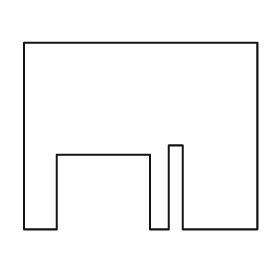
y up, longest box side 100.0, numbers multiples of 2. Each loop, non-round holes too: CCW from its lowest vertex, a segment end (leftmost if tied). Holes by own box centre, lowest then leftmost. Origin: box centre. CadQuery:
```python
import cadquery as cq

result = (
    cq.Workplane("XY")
    .moveTo(-50.0, -40.0)
    .lineTo(-36.0, -40.0)
    .lineTo(-36.0, -8.0)
    .lineTo(4.0, -8.0)
    .lineTo(4.0, -40.0)
    .lineTo(12.0, -40.0)
    .lineTo(12.0, -4.0)
    .lineTo(18.0, -4.0)
    .lineTo(18.0, -40.0)
    .lineTo(50.0, -40.0)
    .lineTo(50.0, 40.0)
    .lineTo(-50.0, 40.0)
    .close()
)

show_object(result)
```